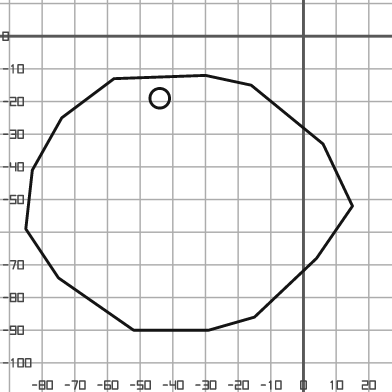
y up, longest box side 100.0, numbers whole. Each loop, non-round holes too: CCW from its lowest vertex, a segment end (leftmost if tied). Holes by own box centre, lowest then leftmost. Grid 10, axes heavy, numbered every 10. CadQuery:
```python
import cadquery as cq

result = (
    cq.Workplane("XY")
    .moveTo(-52.0, -90.0)
    .lineTo(-29.0, -90.0)
    .lineTo(-15.0, -86.0)
    .lineTo(4.0, -68.0)
    .lineTo(15.0, -52.0)
    .lineTo(6.0, -33.0)
    .lineTo(-16.0, -15.0)
    .lineTo(-30.0, -12.0)
    .lineTo(-58.0, -13.0)
    .lineTo(-74.0, -25.0)
    .lineTo(-83.0, -41.0)
    .lineTo(-85.0, -59.0)
    .lineTo(-75.0, -74.0)
    .close()
    .moveTo(-44.0, -19.0)
    .circle(3.0)
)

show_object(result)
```